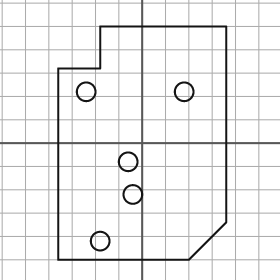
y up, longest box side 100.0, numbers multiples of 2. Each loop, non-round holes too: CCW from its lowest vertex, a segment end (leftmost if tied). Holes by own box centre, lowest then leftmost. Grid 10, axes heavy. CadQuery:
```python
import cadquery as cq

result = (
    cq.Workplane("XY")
    .moveTo(-36.0, -50.0)
    .lineTo(20.0, -50.0)
    .lineTo(36.0, -34.0)
    .lineTo(36.0, 50.0)
    .lineTo(-18.0, 50.0)
    .lineTo(-18.0, 32.0)
    .lineTo(-36.0, 32.0)
    .close()
    .moveTo(-18.0, -42.0)
    .circle(4.0)
    .moveTo(-4.0, -22.0)
    .circle(4.0)
    .moveTo(-6.0, -8.0)
    .circle(4.0)
    .moveTo(-24.0, 22.0)
    .circle(4.0)
    .moveTo(18.0, 22.0)
    .circle(4.0)
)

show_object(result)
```